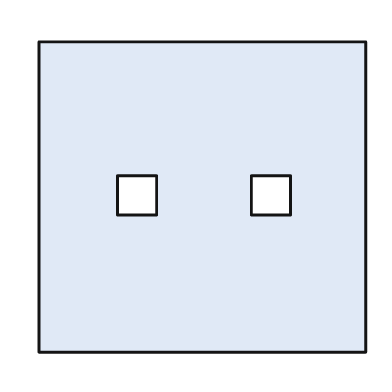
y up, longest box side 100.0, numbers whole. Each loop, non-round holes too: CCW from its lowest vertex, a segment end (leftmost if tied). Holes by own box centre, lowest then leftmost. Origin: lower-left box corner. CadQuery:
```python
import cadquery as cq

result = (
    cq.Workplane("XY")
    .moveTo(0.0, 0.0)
    .lineTo(100.0, 0.0)
    .lineTo(100.0, 95.0)
    .lineTo(0.0, 95.0)
    .close()
    .moveTo(24.0, 42.0)
    .lineTo(36.0, 42.0)
    .lineTo(36.0, 54.0)
    .lineTo(24.0, 54.0)
    .close()
    .moveTo(65.0, 42.0)
    .lineTo(77.0, 42.0)
    .lineTo(77.0, 54.0)
    .lineTo(65.0, 54.0)
    .close()
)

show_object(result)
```